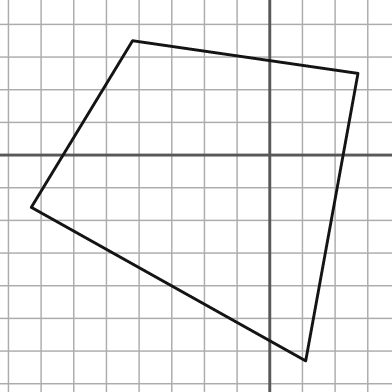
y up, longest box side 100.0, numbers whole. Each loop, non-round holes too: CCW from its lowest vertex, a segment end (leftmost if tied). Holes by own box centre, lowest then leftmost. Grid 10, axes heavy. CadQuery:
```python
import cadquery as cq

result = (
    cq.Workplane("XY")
    .moveTo(11.0, -63.0)
    .lineTo(27.0, 25.0)
    .lineTo(-42.0, 35.0)
    .lineTo(-73.0, -16.0)
    .close()
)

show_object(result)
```